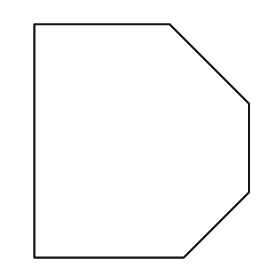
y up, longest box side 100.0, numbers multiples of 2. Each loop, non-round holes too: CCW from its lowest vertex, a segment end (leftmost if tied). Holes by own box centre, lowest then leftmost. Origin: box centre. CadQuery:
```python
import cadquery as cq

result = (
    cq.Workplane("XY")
    .moveTo(-46.0, -50.0)
    .lineTo(18.0, -50.0)
    .lineTo(46.0, -22.0)
    .lineTo(46.0, 16.0)
    .lineTo(12.0, 50.0)
    .lineTo(-46.0, 50.0)
    .close()
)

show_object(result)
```